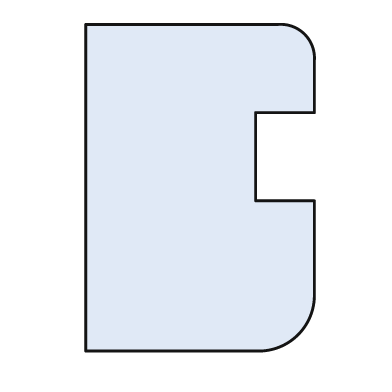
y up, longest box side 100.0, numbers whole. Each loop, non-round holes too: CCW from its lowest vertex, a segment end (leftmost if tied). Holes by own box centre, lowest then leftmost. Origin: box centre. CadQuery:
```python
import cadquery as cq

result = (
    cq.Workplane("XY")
    .moveTo(-35.0, -50.0)
    .lineTo(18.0, -50.0)
    .threePointArc((30.0, -45.0), (35.0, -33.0))
    .lineTo(35.0, -4.0)
    .lineTo(17.0, -4.0)
    .lineTo(17.0, 23.0)
    .lineTo(35.0, 23.0)
    .lineTo(35.0, 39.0)
    .threePointArc((32.0, 47.0), (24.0, 50.0))
    .lineTo(-35.0, 50.0)
    .close()
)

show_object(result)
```